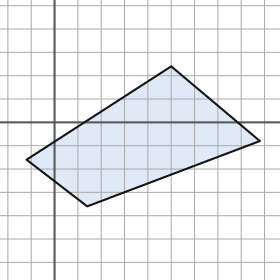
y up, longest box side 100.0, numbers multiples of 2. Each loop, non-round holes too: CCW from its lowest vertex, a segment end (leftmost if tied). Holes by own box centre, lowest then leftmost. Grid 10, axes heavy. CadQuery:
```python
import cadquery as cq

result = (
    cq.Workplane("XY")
    .moveTo(14.0, -36.0)
    .lineTo(88.0, -8.0)
    .lineTo(50.0, 24.0)
    .lineTo(-12.0, -16.0)
    .close()
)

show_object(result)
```